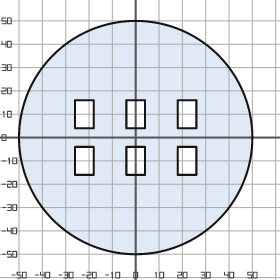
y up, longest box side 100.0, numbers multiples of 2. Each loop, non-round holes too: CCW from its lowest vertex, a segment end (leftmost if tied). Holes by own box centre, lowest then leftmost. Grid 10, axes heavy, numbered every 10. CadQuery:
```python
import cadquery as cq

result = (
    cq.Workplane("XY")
    .moveTo(0.0, 0.0)
    .circle(50.0)
    .moveTo(-26.0, -16.0)
    .lineTo(-18.0, -16.0)
    .lineTo(-18.0, -4.0)
    .lineTo(-26.0, -4.0)
    .close()
    .moveTo(-4.0, -16.0)
    .lineTo(4.0, -16.0)
    .lineTo(4.0, -4.0)
    .lineTo(-4.0, -4.0)
    .close()
    .moveTo(18.0, -16.0)
    .lineTo(26.0, -16.0)
    .lineTo(26.0, -4.0)
    .lineTo(18.0, -4.0)
    .close()
    .moveTo(-26.0, 4.0)
    .lineTo(-18.0, 4.0)
    .lineTo(-18.0, 16.0)
    .lineTo(-26.0, 16.0)
    .close()
    .moveTo(-4.0, 4.0)
    .lineTo(4.0, 4.0)
    .lineTo(4.0, 16.0)
    .lineTo(-4.0, 16.0)
    .close()
    .moveTo(18.0, 4.0)
    .lineTo(26.0, 4.0)
    .lineTo(26.0, 16.0)
    .lineTo(18.0, 16.0)
    .close()
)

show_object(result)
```